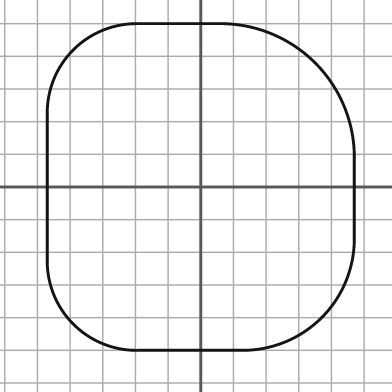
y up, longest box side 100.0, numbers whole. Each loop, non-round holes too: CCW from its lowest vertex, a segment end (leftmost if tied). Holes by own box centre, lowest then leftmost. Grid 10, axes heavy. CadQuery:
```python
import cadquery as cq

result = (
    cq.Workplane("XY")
    .moveTo(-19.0, -50.0)
    .lineTo(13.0, -50.0)
    .threePointArc((37.0, -40.0), (47.0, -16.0))
    .lineTo(47.0, 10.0)
    .threePointArc((35.0, 38.0), (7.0, 50.0))
    .lineTo(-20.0, 50.0)
    .threePointArc((-39.0, 42.0), (-47.0, 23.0))
    .lineTo(-47.0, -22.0)
    .threePointArc((-39.0, -42.0), (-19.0, -50.0))
    .close()
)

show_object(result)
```